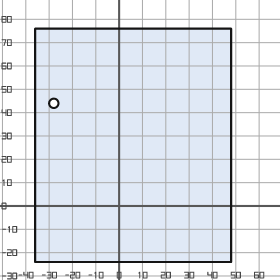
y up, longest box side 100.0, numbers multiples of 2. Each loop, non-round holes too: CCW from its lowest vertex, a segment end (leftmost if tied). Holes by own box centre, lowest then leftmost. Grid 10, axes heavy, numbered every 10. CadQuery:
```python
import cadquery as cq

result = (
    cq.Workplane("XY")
    .moveTo(-36.0, -24.0)
    .lineTo(48.0, -24.0)
    .lineTo(48.0, 76.0)
    .lineTo(-36.0, 76.0)
    .close()
    .moveTo(-28.0, 44.0)
    .circle(2.0)
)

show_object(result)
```